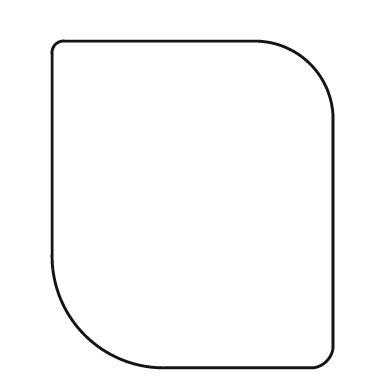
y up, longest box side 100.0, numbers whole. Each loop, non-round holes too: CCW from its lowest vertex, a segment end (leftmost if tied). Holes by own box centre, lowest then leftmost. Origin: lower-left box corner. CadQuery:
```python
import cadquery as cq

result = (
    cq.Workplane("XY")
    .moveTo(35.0, 0.0)
    .lineTo(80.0, 0.0)
    .threePointArc((84.0, 2.0), (86.0, 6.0))
    .lineTo(86.0, 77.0)
    .threePointArc((79.0, 93.0), (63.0, 100.0))
    .lineTo(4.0, 100.0)
    .threePointArc((1.0, 99.0), (0.0, 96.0))
    .lineTo(0.0, 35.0)
    .threePointArc((10.0, 10.0), (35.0, 0.0))
    .close()
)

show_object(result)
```